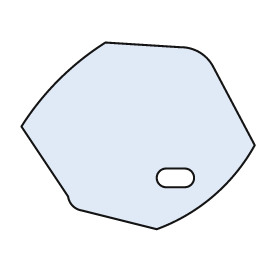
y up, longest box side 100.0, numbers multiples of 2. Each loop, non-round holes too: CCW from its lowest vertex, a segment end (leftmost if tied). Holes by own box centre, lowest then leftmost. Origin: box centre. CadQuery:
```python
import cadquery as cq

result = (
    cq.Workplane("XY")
    .moveTo(8.0, -40.0)
    .threePointArc((32.0, -26.0), (50.0, -4.0))
    .lineTo(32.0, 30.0)
    .threePointArc((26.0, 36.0), (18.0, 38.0))
    .lineTo(-14.0, 40.0)
    .threePointArc((-34.0, 24.0), (-50.0, 4.0))
    .lineTo(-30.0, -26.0)
    .threePointArc((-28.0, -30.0), (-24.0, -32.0))
    .close()
    .moveTo(12.0, -22.0)
    .lineTo(20.0, -22.0)
    .threePointArc((24.0, -18.0), (20.0, -14.0))
    .lineTo(12.0, -14.0)
    .threePointArc((8.0, -18.0), (12.0, -22.0))
    .close()
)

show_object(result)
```